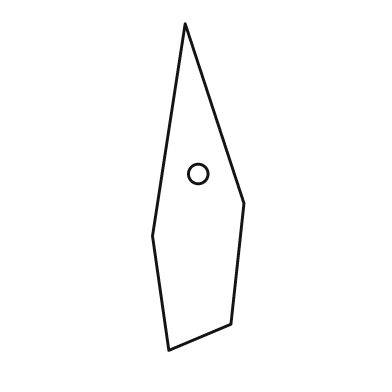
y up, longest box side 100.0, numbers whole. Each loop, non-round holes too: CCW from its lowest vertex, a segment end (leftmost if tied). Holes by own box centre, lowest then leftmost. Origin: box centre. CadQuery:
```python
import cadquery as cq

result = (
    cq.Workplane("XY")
    .moveTo(-9.0, -50.0)
    .lineTo(10.0, -42.0)
    .lineTo(14.0, -5.0)
    .lineTo(-4.0, 50.0)
    .lineTo(-14.0, -15.0)
    .close()
    .moveTo(0.0, 4.0)
    .circle(3.0)
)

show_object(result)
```